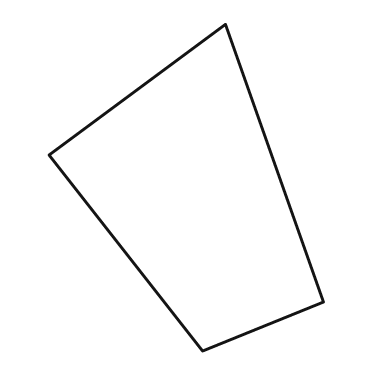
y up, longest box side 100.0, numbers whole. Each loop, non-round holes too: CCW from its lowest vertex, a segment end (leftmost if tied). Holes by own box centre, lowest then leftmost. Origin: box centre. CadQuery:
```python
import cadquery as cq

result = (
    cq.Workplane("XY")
    .moveTo(5.0, -50.0)
    .lineTo(42.0, -35.0)
    .lineTo(12.0, 50.0)
    .lineTo(-42.0, 10.0)
    .close()
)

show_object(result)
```